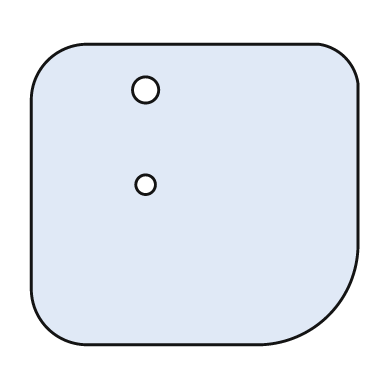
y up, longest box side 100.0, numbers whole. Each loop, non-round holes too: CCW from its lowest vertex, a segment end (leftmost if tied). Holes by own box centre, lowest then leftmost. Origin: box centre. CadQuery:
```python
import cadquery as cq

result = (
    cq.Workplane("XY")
    .moveTo(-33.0, -46.0)
    .lineTo(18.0, -46.0)
    .threePointArc((41.0, -37.0), (50.0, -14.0))
    .lineTo(50.0, 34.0)
    .threePointArc((46.0, 42.0), (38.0, 46.0))
    .lineTo(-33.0, 46.0)
    .threePointArc((-45.0, 41.0), (-50.0, 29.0))
    .lineTo(-50.0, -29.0)
    .threePointArc((-45.0, -41.0), (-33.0, -46.0))
    .close()
    .moveTo(-15.0, 3.0)
    .circle(3.0)
    .moveTo(-15.0, 32.0)
    .circle(4.0)
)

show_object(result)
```